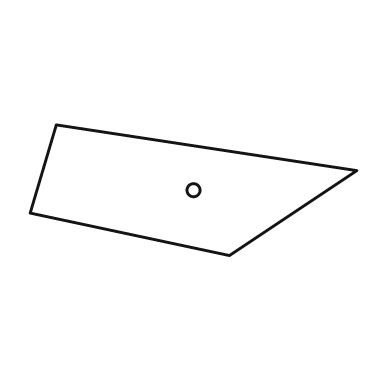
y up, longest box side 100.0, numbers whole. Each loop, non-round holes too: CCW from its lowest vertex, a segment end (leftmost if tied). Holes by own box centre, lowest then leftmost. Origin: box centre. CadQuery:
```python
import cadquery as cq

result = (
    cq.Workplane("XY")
    .moveTo(11.0, -20.0)
    .lineTo(50.0, 6.0)
    .lineTo(-42.0, 20.0)
    .lineTo(-50.0, -7.0)
    .close()
    .moveTo(0.0, 0.0)
    .circle(2.0)
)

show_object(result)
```